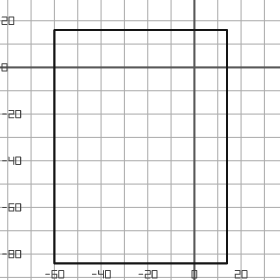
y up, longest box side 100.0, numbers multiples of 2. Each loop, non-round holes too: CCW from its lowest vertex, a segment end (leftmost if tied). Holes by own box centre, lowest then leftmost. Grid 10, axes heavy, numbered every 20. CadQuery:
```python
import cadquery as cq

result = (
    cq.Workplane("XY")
    .moveTo(-60.0, -84.0)
    .lineTo(14.0, -84.0)
    .lineTo(14.0, 16.0)
    .lineTo(-60.0, 16.0)
    .close()
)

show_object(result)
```